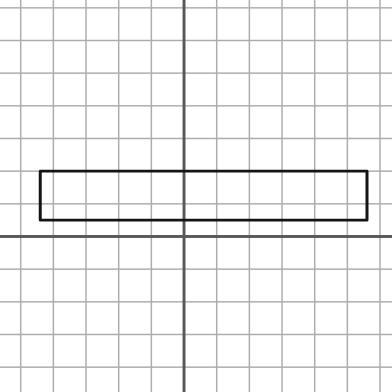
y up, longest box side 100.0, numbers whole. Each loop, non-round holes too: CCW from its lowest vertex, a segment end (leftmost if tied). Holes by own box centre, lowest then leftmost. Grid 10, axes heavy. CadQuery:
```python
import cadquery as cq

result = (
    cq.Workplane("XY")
    .moveTo(-44.0, 5.0)
    .lineTo(56.0, 5.0)
    .lineTo(56.0, 20.0)
    .lineTo(-44.0, 20.0)
    .close()
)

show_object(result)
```